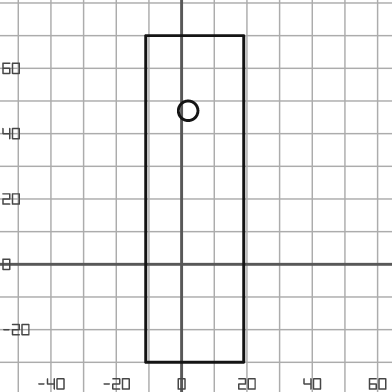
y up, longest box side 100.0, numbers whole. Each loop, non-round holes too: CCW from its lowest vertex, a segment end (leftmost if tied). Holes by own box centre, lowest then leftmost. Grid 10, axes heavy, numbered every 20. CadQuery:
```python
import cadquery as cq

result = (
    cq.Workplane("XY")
    .moveTo(-11.0, -30.0)
    .lineTo(19.0, -30.0)
    .lineTo(19.0, 70.0)
    .lineTo(-11.0, 70.0)
    .close()
    .moveTo(2.0, 47.0)
    .circle(3.0)
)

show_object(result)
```